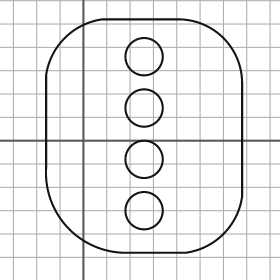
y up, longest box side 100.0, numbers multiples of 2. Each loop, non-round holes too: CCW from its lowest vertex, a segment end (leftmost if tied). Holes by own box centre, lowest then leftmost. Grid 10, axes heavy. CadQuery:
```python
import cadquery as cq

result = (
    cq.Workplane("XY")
    .moveTo(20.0, -48.0)
    .lineTo(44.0, -48.0)
    .threePointArc((60.0, -40.0), (68.0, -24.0))
    .lineTo(68.0, 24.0)
    .threePointArc((60.0, 44.0), (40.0, 52.0))
    .lineTo(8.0, 52.0)
    .threePointArc((-8.0, 44.0), (-16.0, 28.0))
    .lineTo(-16.0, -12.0)
    .threePointArc((-6.0, -38.0), (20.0, -48.0))
    .close()
    .moveTo(26.0, -30.0)
    .circle(8.0)
    .moveTo(26.0, -8.0)
    .circle(8.0)
    .moveTo(26.0, 14.0)
    .circle(8.0)
    .moveTo(26.0, 36.0)
    .circle(8.0)
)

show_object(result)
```